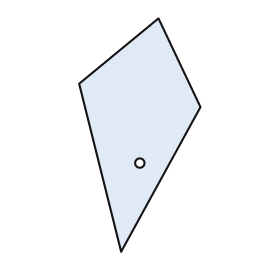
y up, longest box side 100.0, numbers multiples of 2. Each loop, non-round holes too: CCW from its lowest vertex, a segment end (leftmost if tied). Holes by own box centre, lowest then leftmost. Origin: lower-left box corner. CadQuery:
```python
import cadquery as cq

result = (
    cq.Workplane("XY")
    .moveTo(18.0, 0.0)
    .lineTo(52.0, 62.0)
    .lineTo(34.0, 100.0)
    .lineTo(0.0, 72.0)
    .close()
    .moveTo(26.0, 38.0)
    .circle(2.0)
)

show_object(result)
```